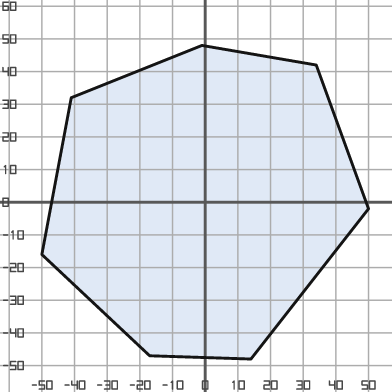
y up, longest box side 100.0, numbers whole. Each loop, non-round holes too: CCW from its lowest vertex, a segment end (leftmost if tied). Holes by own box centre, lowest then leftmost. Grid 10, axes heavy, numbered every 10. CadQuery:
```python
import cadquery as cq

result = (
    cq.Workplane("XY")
    .moveTo(14.0, -48.0)
    .lineTo(50.0, -2.0)
    .lineTo(34.0, 42.0)
    .lineTo(-1.0, 48.0)
    .lineTo(-41.0, 32.0)
    .lineTo(-50.0, -16.0)
    .lineTo(-17.0, -47.0)
    .close()
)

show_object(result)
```